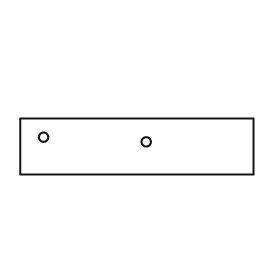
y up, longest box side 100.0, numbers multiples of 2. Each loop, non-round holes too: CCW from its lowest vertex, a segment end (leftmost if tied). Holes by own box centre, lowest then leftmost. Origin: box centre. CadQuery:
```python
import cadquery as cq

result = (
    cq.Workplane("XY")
    .moveTo(-50.0, -12.0)
    .lineTo(50.0, -12.0)
    .lineTo(50.0, 12.0)
    .lineTo(-50.0, 12.0)
    .close()
    .moveTo(4.0, 2.0)
    .circle(2.0)
    .moveTo(-40.0, 4.0)
    .circle(2.0)
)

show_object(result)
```